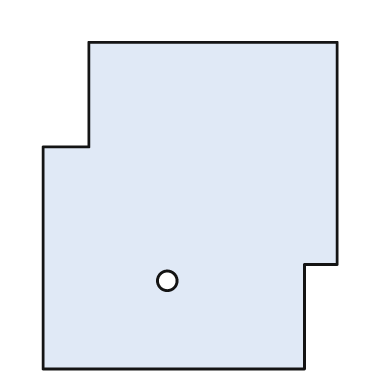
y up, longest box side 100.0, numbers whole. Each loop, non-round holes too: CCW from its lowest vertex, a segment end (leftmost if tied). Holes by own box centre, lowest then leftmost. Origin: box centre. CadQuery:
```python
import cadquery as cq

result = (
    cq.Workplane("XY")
    .moveTo(-45.0, -50.0)
    .lineTo(35.0, -50.0)
    .lineTo(35.0, -18.0)
    .lineTo(45.0, -18.0)
    .lineTo(45.0, 50.0)
    .lineTo(-31.0, 50.0)
    .lineTo(-31.0, 18.0)
    .lineTo(-45.0, 18.0)
    .close()
    .moveTo(-7.0, -23.0)
    .circle(3.0)
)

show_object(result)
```